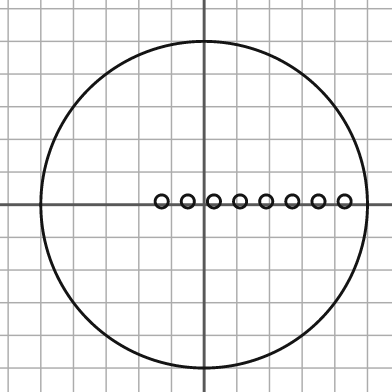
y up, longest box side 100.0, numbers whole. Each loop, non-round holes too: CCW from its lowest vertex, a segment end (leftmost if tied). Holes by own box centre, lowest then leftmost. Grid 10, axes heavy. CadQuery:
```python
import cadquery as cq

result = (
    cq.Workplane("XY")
    .moveTo(0.0, 0.0)
    .circle(50.0)
    .moveTo(-13.0, 1.0)
    .circle(2.0)
    .moveTo(-5.0, 1.0)
    .circle(2.0)
    .moveTo(3.0, 1.0)
    .circle(2.0)
    .moveTo(11.0, 1.0)
    .circle(2.0)
    .moveTo(19.0, 1.0)
    .circle(2.0)
    .moveTo(27.0, 1.0)
    .circle(2.0)
    .moveTo(35.0, 1.0)
    .circle(2.0)
    .moveTo(43.0, 1.0)
    .circle(2.0)
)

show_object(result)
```